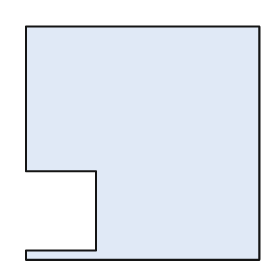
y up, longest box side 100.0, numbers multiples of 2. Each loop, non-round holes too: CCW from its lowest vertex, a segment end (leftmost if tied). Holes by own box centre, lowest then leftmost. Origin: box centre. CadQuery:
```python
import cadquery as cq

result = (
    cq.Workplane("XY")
    .moveTo(-50.0, -50.0)
    .lineTo(50.0, -50.0)
    .lineTo(50.0, 50.0)
    .lineTo(-50.0, 50.0)
    .lineTo(-50.0, -12.0)
    .lineTo(-20.0, -12.0)
    .lineTo(-20.0, -46.0)
    .lineTo(-50.0, -46.0)
    .close()
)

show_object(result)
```